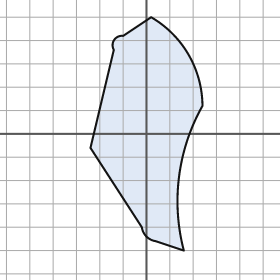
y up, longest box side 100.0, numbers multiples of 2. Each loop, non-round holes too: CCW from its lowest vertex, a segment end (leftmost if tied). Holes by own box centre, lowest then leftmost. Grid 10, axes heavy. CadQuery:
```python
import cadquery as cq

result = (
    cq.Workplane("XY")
    .moveTo(16.0, -50.0)
    .threePointArc((14.0, -18.0), (24.0, 12.0))
    .threePointArc((18.0, 34.0), (2.0, 50.0))
    .lineTo(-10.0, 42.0)
    .threePointArc((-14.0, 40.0), (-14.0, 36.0))
    .lineTo(-24.0, -6.0)
    .lineTo(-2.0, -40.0)
    .threePointArc((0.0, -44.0), (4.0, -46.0))
    .close()
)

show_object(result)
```